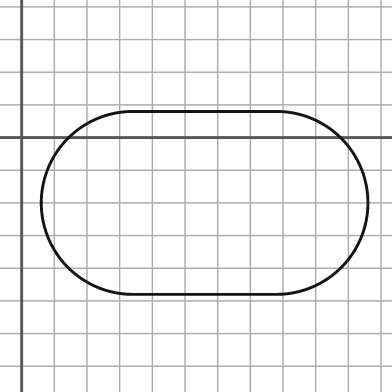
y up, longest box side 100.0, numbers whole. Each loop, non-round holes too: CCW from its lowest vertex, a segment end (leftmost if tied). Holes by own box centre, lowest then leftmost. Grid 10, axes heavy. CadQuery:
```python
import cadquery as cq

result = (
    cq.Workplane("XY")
    .moveTo(34.0, -48.0)
    .lineTo(78.0, -48.0)
    .threePointArc((106.0, -20.0), (78.0, 8.0))
    .lineTo(34.0, 8.0)
    .threePointArc((6.0, -20.0), (34.0, -48.0))
    .close()
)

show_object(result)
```